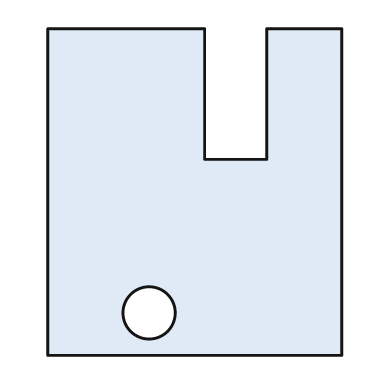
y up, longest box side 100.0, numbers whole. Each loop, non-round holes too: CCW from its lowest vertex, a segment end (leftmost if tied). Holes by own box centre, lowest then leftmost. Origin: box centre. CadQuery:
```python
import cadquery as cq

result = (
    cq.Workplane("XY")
    .moveTo(-45.0, -50.0)
    .lineTo(45.0, -50.0)
    .lineTo(45.0, 50.0)
    .lineTo(22.0, 50.0)
    .lineTo(22.0, 10.0)
    .lineTo(3.0, 10.0)
    .lineTo(3.0, 50.0)
    .lineTo(-45.0, 50.0)
    .close()
    .moveTo(-14.0, -37.0)
    .circle(8.0)
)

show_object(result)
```